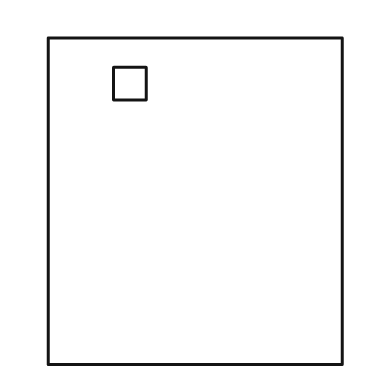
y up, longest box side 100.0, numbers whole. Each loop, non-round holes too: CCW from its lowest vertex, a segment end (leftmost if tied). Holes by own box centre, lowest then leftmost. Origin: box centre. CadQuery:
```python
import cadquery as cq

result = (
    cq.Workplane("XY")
    .moveTo(-45.0, -50.0)
    .lineTo(45.0, -50.0)
    .lineTo(45.0, 50.0)
    .lineTo(-45.0, 50.0)
    .close()
    .moveTo(-25.0, 31.0)
    .lineTo(-15.0, 31.0)
    .lineTo(-15.0, 41.0)
    .lineTo(-25.0, 41.0)
    .close()
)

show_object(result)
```